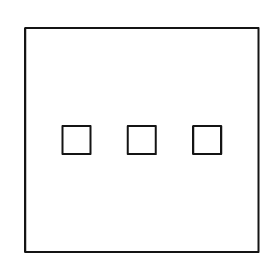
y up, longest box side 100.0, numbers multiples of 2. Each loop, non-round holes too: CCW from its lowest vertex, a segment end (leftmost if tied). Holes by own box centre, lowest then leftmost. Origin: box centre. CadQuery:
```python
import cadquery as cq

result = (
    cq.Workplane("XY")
    .moveTo(-50.0, -48.0)
    .lineTo(50.0, -48.0)
    .lineTo(50.0, 48.0)
    .lineTo(-50.0, 48.0)
    .close()
    .moveTo(-34.0, -6.0)
    .lineTo(-22.0, -6.0)
    .lineTo(-22.0, 6.0)
    .lineTo(-34.0, 6.0)
    .close()
    .moveTo(-6.0, -6.0)
    .lineTo(6.0, -6.0)
    .lineTo(6.0, 6.0)
    .lineTo(-6.0, 6.0)
    .close()
    .moveTo(22.0, -6.0)
    .lineTo(34.0, -6.0)
    .lineTo(34.0, 6.0)
    .lineTo(22.0, 6.0)
    .close()
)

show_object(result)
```